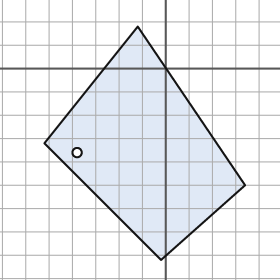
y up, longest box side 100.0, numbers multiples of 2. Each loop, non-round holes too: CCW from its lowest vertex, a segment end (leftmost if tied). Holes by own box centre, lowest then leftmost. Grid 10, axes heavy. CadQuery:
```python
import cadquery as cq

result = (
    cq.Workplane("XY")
    .moveTo(-2.0, -82.0)
    .lineTo(34.0, -50.0)
    .lineTo(-12.0, 18.0)
    .lineTo(-52.0, -32.0)
    .close()
    .moveTo(-38.0, -36.0)
    .circle(2.0)
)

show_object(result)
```